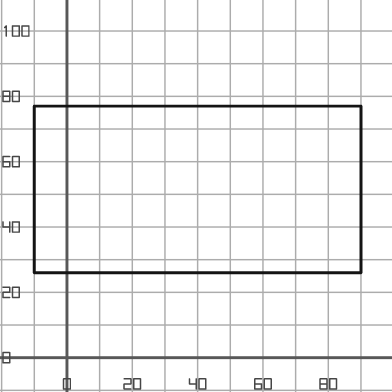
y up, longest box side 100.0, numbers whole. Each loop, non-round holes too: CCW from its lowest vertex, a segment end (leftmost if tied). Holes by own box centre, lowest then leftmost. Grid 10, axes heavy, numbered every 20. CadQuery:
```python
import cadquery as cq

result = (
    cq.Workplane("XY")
    .moveTo(-10.0, 26.0)
    .lineTo(90.0, 26.0)
    .lineTo(90.0, 77.0)
    .lineTo(-10.0, 77.0)
    .close()
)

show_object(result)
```